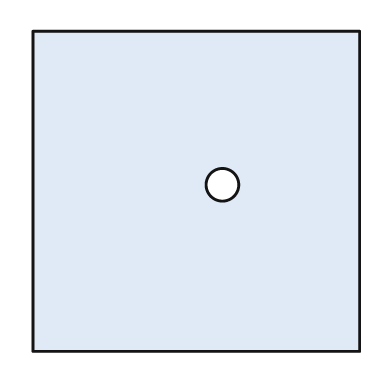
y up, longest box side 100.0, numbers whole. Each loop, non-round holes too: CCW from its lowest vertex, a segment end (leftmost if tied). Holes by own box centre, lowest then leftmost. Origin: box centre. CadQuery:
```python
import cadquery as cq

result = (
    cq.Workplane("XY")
    .moveTo(-50.0, -49.0)
    .lineTo(50.0, -49.0)
    .lineTo(50.0, 49.0)
    .lineTo(-50.0, 49.0)
    .close()
    .moveTo(8.0, 2.0)
    .circle(5.0)
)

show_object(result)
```